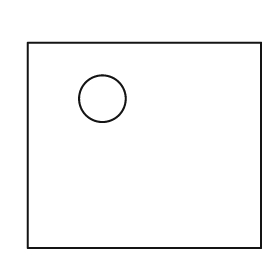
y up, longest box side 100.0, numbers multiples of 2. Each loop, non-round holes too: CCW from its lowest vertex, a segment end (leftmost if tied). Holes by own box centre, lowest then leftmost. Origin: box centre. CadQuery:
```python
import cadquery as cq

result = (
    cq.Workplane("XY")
    .moveTo(-50.0, -44.0)
    .lineTo(50.0, -44.0)
    .lineTo(50.0, 44.0)
    .lineTo(-50.0, 44.0)
    .close()
    .moveTo(-18.0, 20.0)
    .circle(10.0)
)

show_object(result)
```